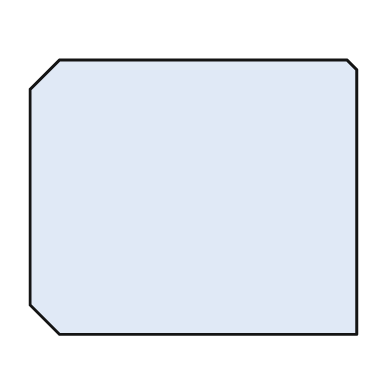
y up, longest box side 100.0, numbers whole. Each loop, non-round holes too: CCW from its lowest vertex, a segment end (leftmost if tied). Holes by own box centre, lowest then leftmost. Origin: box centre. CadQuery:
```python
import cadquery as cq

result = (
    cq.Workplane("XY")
    .moveTo(-41.0, -42.0)
    .lineTo(50.0, -42.0)
    .lineTo(50.0, 39.0)
    .lineTo(47.0, 42.0)
    .lineTo(-41.0, 42.0)
    .lineTo(-50.0, 33.0)
    .lineTo(-50.0, -33.0)
    .close()
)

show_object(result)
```